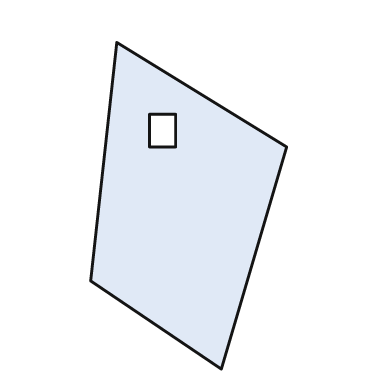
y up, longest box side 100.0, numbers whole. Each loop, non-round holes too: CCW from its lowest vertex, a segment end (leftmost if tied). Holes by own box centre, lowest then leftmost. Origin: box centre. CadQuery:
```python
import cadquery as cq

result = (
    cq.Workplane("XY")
    .moveTo(10.0, -50.0)
    .lineTo(30.0, 18.0)
    .lineTo(-22.0, 50.0)
    .lineTo(-30.0, -23.0)
    .close()
    .moveTo(-12.0, 18.0)
    .lineTo(-4.0, 18.0)
    .lineTo(-4.0, 28.0)
    .lineTo(-12.0, 28.0)
    .close()
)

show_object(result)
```